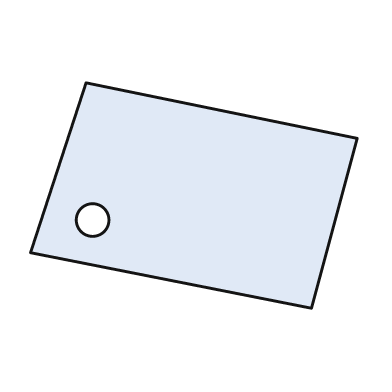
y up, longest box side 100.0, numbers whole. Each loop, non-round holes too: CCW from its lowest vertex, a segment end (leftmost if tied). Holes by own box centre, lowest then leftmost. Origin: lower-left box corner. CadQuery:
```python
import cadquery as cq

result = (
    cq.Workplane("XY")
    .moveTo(86.0, 0.0)
    .lineTo(100.0, 52.0)
    .lineTo(17.0, 69.0)
    .lineTo(0.0, 17.0)
    .close()
    .moveTo(19.0, 27.0)
    .circle(5.0)
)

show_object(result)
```